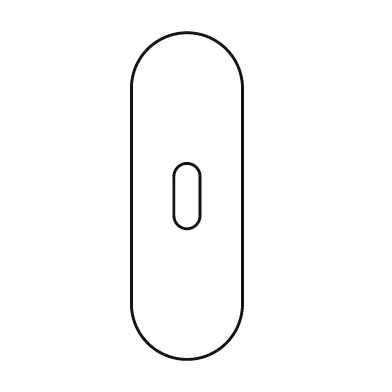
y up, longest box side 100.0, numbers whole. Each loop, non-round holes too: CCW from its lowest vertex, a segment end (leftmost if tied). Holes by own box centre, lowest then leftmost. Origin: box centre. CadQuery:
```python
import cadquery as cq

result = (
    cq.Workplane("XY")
    .moveTo(-17.0, -33.0)
    .threePointArc((0.0, -50.0), (17.0, -33.0))
    .lineTo(17.0, 33.0)
    .threePointArc((0.0, 50.0), (-17.0, 33.0))
    .close()
    .moveTo(-4.0, -6.0)
    .threePointArc((0.0, -10.0), (4.0, -6.0))
    .lineTo(4.0, 6.0)
    .threePointArc((0.0, 10.0), (-4.0, 6.0))
    .close()
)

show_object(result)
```